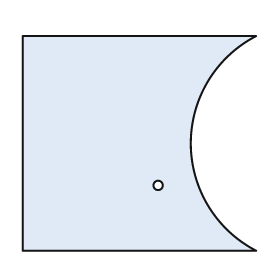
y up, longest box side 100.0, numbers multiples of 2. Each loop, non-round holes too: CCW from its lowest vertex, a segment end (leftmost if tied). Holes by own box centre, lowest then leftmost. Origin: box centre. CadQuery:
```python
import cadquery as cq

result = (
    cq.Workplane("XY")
    .moveTo(-50.0, -46.0)
    .lineTo(50.0, -46.0)
    .threePointArc((22.0, 0.0), (50.0, 46.0))
    .lineTo(-50.0, 46.0)
    .close()
    .moveTo(8.0, -18.0)
    .circle(2.0)
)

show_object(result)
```